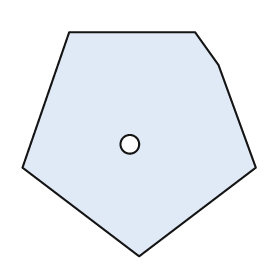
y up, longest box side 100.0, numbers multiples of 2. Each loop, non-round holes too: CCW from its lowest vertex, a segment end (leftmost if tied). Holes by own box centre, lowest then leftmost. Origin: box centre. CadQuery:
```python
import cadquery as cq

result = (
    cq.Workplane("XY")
    .moveTo(0.0, -48.0)
    .lineTo(50.0, -10.0)
    .lineTo(34.0, 34.0)
    .lineTo(24.0, 48.0)
    .lineTo(-30.0, 48.0)
    .lineTo(-50.0, -10.0)
    .close()
    .moveTo(-4.0, 0.0)
    .circle(4.0)
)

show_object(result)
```